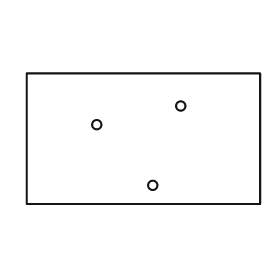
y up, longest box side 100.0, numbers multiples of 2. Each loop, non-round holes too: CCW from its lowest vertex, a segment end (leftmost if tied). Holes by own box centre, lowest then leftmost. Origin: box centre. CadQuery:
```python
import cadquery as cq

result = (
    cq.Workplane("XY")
    .moveTo(-50.0, -28.0)
    .lineTo(50.0, -28.0)
    .lineTo(50.0, 28.0)
    .lineTo(-50.0, 28.0)
    .close()
    .moveTo(4.0, -20.0)
    .circle(2.0)
    .moveTo(-20.0, 6.0)
    .circle(2.0)
    .moveTo(16.0, 14.0)
    .circle(2.0)
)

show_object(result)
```